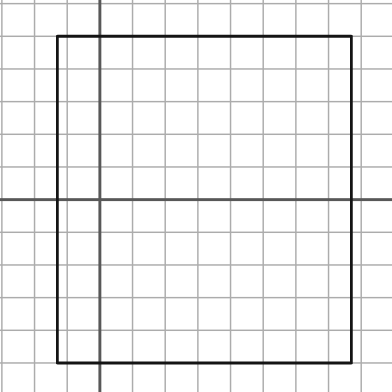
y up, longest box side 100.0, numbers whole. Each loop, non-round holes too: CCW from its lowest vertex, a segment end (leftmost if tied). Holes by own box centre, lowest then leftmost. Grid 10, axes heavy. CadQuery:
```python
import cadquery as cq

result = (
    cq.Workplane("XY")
    .moveTo(-13.0, -50.0)
    .lineTo(77.0, -50.0)
    .lineTo(77.0, 50.0)
    .lineTo(-13.0, 50.0)
    .close()
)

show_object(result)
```